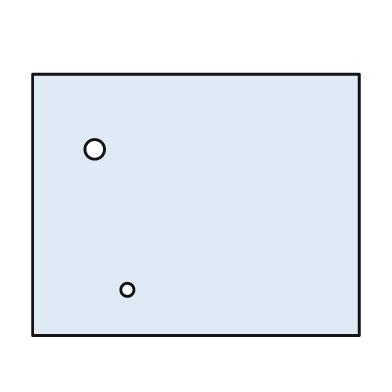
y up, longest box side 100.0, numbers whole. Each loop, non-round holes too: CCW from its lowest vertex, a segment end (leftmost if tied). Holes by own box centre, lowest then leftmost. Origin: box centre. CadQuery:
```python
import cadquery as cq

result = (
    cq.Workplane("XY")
    .moveTo(-50.0, -40.0)
    .lineTo(50.0, -40.0)
    .lineTo(50.0, 40.0)
    .lineTo(-50.0, 40.0)
    .close()
    .moveTo(-21.0, -26.0)
    .circle(2.0)
    .moveTo(-31.0, 17.0)
    .circle(3.0)
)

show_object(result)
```